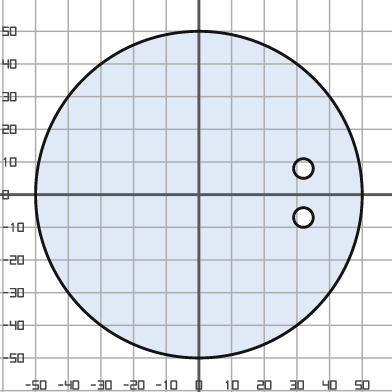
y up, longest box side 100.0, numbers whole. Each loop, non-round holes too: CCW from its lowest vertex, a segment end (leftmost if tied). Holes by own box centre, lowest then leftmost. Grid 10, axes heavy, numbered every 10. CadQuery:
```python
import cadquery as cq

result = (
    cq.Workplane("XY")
    .moveTo(0.0, 0.0)
    .circle(50.0)
    .moveTo(32.0, -7.0)
    .circle(3.0)
    .moveTo(32.0, 8.0)
    .circle(3.0)
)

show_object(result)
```